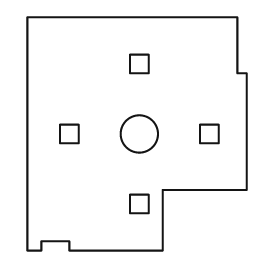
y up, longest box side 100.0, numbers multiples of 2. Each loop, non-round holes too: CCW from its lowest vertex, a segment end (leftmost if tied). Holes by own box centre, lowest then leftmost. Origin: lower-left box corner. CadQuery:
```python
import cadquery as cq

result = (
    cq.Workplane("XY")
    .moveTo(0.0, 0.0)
    .lineTo(6.0, 0.0)
    .lineTo(6.0, 4.0)
    .lineTo(18.0, 4.0)
    .lineTo(18.0, 0.0)
    .lineTo(58.0, 0.0)
    .lineTo(58.0, 26.0)
    .lineTo(94.0, 26.0)
    .lineTo(94.0, 76.0)
    .lineTo(90.0, 76.0)
    .lineTo(90.0, 100.0)
    .lineTo(0.0, 100.0)
    .close()
    .moveTo(44.0, 16.0)
    .lineTo(52.0, 16.0)
    .lineTo(52.0, 24.0)
    .lineTo(44.0, 24.0)
    .close()
    .moveTo(14.0, 46.0)
    .lineTo(22.0, 46.0)
    .lineTo(22.0, 54.0)
    .lineTo(14.0, 54.0)
    .close()
    .moveTo(48.0, 50.0)
    .circle(8.0)
    .moveTo(74.0, 46.0)
    .lineTo(82.0, 46.0)
    .lineTo(82.0, 54.0)
    .lineTo(74.0, 54.0)
    .close()
    .moveTo(44.0, 76.0)
    .lineTo(52.0, 76.0)
    .lineTo(52.0, 84.0)
    .lineTo(44.0, 84.0)
    .close()
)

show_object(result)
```